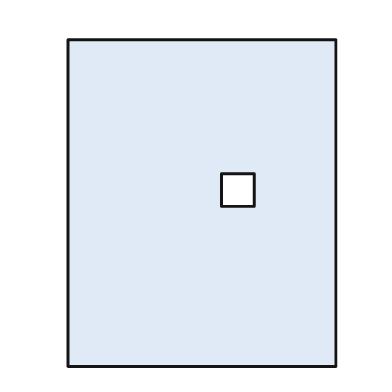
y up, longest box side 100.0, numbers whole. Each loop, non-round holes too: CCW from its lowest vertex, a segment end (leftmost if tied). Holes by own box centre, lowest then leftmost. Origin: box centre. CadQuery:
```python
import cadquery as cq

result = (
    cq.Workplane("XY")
    .moveTo(-41.0, -50.0)
    .lineTo(41.0, -50.0)
    .lineTo(41.0, 50.0)
    .lineTo(-41.0, 50.0)
    .close()
    .moveTo(6.0, -1.0)
    .lineTo(16.0, -1.0)
    .lineTo(16.0, 9.0)
    .lineTo(6.0, 9.0)
    .close()
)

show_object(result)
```